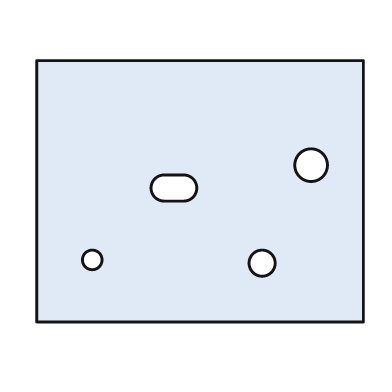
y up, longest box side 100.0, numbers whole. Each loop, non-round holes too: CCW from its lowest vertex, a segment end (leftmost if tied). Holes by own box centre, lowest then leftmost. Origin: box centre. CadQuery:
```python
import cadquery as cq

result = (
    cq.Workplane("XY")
    .moveTo(-50.0, -40.0)
    .lineTo(50.0, -40.0)
    .lineTo(50.0, 40.0)
    .lineTo(-50.0, 40.0)
    .close()
    .moveTo(19.0, -22.0)
    .circle(4.0)
    .moveTo(-33.0, -21.0)
    .circle(3.0)
    .moveTo(-11.0, -3.0)
    .lineTo(-5.0, -3.0)
    .threePointArc((-1.0, 1.0), (-5.0, 5.0))
    .lineTo(-11.0, 5.0)
    .threePointArc((-15.0, 1.0), (-11.0, -3.0))
    .close()
    .moveTo(34.0, 8.0)
    .circle(5.0)
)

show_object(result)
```